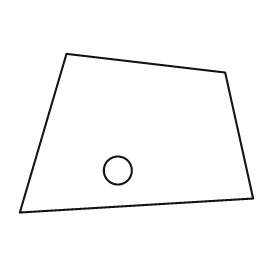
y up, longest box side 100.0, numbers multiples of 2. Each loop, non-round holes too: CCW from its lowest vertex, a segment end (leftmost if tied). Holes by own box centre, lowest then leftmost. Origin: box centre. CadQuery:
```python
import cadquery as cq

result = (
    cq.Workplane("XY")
    .moveTo(-50.0, -34.0)
    .lineTo(50.0, -28.0)
    .lineTo(38.0, 26.0)
    .lineTo(-30.0, 34.0)
    .close()
    .moveTo(-8.0, -16.0)
    .circle(6.0)
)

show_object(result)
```